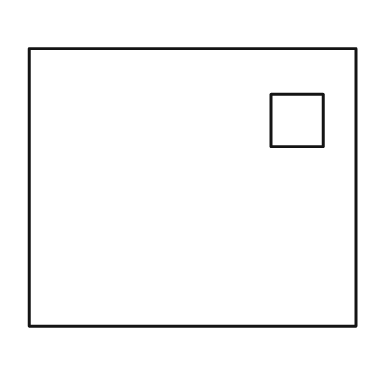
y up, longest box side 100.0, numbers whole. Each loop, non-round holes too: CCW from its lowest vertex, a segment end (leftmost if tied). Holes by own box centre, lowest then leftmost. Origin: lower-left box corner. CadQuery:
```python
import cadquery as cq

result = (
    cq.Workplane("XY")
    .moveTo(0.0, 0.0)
    .lineTo(100.0, 0.0)
    .lineTo(100.0, 85.0)
    .lineTo(0.0, 85.0)
    .close()
    .moveTo(74.0, 55.0)
    .lineTo(90.0, 55.0)
    .lineTo(90.0, 71.0)
    .lineTo(74.0, 71.0)
    .close()
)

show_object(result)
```